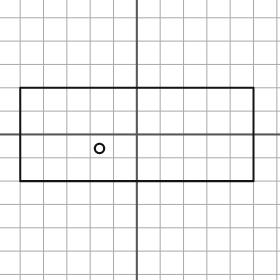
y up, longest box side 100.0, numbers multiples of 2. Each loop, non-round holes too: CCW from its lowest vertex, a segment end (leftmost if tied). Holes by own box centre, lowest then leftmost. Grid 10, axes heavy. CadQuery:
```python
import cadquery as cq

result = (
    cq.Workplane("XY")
    .moveTo(-50.0, -20.0)
    .lineTo(50.0, -20.0)
    .lineTo(50.0, 20.0)
    .lineTo(-50.0, 20.0)
    .close()
    .moveTo(-16.0, -6.0)
    .circle(2.0)
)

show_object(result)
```